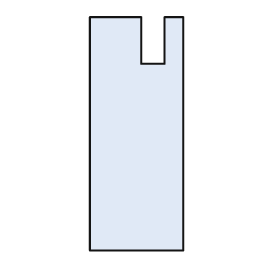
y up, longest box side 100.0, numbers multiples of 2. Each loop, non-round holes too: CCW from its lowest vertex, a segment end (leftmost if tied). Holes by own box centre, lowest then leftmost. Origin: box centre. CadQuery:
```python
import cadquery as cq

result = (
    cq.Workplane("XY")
    .moveTo(-20.0, -50.0)
    .lineTo(20.0, -50.0)
    .lineTo(20.0, 50.0)
    .lineTo(12.0, 50.0)
    .lineTo(12.0, 30.0)
    .lineTo(2.0, 30.0)
    .lineTo(2.0, 50.0)
    .lineTo(-20.0, 50.0)
    .close()
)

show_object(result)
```